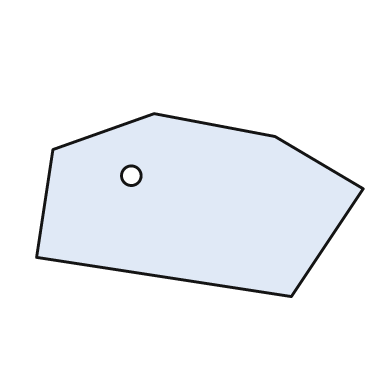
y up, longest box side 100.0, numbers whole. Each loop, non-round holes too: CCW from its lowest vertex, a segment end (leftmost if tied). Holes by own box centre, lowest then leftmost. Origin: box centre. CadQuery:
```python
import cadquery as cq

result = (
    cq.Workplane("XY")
    .moveTo(28.0, -28.0)
    .lineTo(50.0, 5.0)
    .lineTo(23.0, 21.0)
    .lineTo(-14.0, 28.0)
    .lineTo(-45.0, 17.0)
    .lineTo(-50.0, -16.0)
    .close()
    .moveTo(-21.0, 9.0)
    .circle(3.0)
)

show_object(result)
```